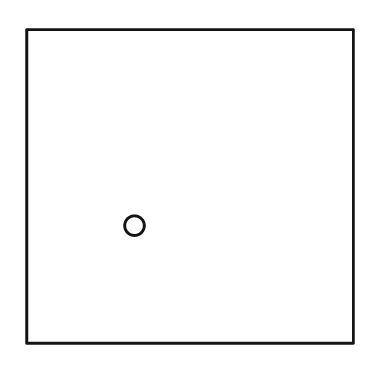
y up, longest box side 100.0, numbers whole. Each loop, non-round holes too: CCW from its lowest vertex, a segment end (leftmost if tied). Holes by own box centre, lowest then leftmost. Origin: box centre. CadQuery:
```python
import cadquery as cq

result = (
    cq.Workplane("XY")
    .moveTo(-50.0, -48.0)
    .lineTo(50.0, -48.0)
    .lineTo(50.0, 48.0)
    .lineTo(-50.0, 48.0)
    .close()
    .moveTo(-17.0, -12.0)
    .circle(3.0)
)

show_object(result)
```